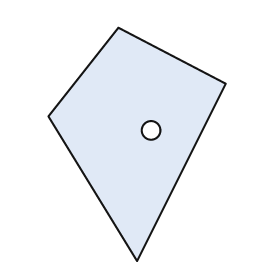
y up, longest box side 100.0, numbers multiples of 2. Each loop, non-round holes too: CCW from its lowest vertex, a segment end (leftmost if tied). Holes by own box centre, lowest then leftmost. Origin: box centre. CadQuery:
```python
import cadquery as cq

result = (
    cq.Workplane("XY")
    .moveTo(0.0, -50.0)
    .lineTo(38.0, 26.0)
    .lineTo(-8.0, 50.0)
    .lineTo(-38.0, 12.0)
    .close()
    .moveTo(6.0, 6.0)
    .circle(4.0)
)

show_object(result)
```